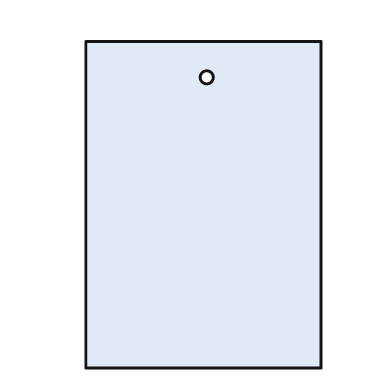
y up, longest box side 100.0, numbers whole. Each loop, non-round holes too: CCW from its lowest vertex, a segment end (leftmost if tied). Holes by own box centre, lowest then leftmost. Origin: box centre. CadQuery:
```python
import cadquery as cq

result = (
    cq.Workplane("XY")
    .moveTo(-36.0, -50.0)
    .lineTo(36.0, -50.0)
    .lineTo(36.0, 50.0)
    .lineTo(-36.0, 50.0)
    .close()
    .moveTo(1.0, 39.0)
    .circle(2.0)
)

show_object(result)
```